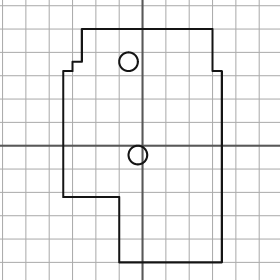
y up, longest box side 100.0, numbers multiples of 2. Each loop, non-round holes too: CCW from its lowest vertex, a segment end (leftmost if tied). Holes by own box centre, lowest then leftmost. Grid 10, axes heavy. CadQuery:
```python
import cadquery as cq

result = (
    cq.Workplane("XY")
    .moveTo(-10.0, -50.0)
    .lineTo(34.0, -50.0)
    .lineTo(34.0, 32.0)
    .lineTo(30.0, 32.0)
    .lineTo(30.0, 50.0)
    .lineTo(-26.0, 50.0)
    .lineTo(-26.0, 36.0)
    .lineTo(-30.0, 36.0)
    .lineTo(-30.0, 32.0)
    .lineTo(-34.0, 32.0)
    .lineTo(-34.0, -22.0)
    .lineTo(-10.0, -22.0)
    .close()
    .moveTo(-2.0, -4.0)
    .circle(4.0)
    .moveTo(-6.0, 36.0)
    .circle(4.0)
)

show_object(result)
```